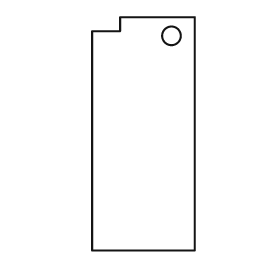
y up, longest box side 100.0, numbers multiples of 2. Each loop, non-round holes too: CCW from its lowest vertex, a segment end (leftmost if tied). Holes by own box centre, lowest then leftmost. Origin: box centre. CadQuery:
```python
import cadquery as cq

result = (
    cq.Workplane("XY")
    .moveTo(-22.0, -50.0)
    .lineTo(22.0, -50.0)
    .lineTo(22.0, 50.0)
    .lineTo(-10.0, 50.0)
    .lineTo(-10.0, 44.0)
    .lineTo(-22.0, 44.0)
    .close()
    .moveTo(12.0, 42.0)
    .circle(4.0)
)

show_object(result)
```